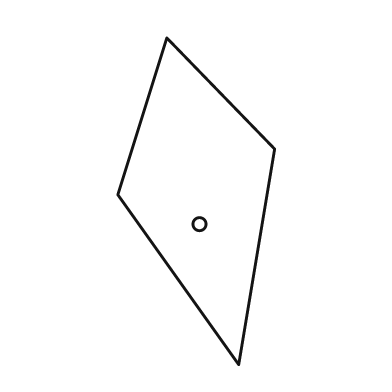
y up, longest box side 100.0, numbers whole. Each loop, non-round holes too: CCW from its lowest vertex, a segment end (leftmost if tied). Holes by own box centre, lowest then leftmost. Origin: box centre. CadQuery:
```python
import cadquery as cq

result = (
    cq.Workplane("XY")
    .moveTo(13.0, -50.0)
    .lineTo(24.0, 16.0)
    .lineTo(-9.0, 50.0)
    .lineTo(-24.0, 2.0)
    .close()
    .moveTo(1.0, -7.0)
    .circle(2.0)
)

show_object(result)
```